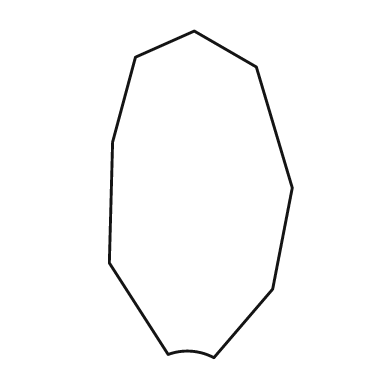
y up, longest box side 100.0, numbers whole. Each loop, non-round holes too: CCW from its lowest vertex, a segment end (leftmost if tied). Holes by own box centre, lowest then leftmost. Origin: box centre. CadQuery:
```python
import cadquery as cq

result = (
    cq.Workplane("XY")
    .moveTo(4.0, -50.0)
    .lineTo(22.0, -29.0)
    .lineTo(28.0, 2.0)
    .lineTo(17.0, 39.0)
    .lineTo(-2.0, 50.0)
    .lineTo(-20.0, 42.0)
    .lineTo(-27.0, 16.0)
    .lineTo(-28.0, -21.0)
    .lineTo(-10.0, -49.0)
    .threePointArc((-3.0, -48.0), (4.0, -50.0))
    .close()
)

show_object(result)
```